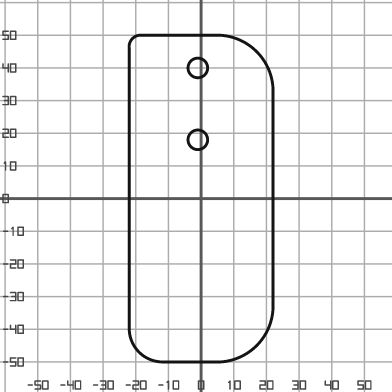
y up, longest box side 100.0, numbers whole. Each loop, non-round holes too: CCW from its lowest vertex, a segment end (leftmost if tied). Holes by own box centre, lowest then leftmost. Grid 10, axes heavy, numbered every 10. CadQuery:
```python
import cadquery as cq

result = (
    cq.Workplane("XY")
    .moveTo(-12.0, -50.0)
    .lineTo(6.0, -50.0)
    .threePointArc((17.0, -45.0), (22.0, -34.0))
    .lineTo(22.0, 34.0)
    .threePointArc((17.0, 45.0), (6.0, 50.0))
    .lineTo(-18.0, 50.0)
    .threePointArc((-21.0, 49.0), (-22.0, 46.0))
    .lineTo(-22.0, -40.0)
    .threePointArc((-19.0, -47.0), (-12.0, -50.0))
    .close()
    .moveTo(-1.0, 18.0)
    .circle(3.0)
    .moveTo(-1.0, 40.0)
    .circle(3.0)
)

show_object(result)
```